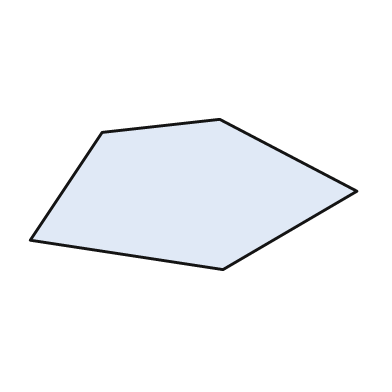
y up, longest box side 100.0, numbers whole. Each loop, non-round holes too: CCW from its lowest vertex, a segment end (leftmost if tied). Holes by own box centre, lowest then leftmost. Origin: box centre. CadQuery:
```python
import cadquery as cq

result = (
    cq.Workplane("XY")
    .moveTo(9.0, -23.0)
    .lineTo(50.0, 1.0)
    .lineTo(8.0, 23.0)
    .lineTo(-28.0, 19.0)
    .lineTo(-50.0, -14.0)
    .close()
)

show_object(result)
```